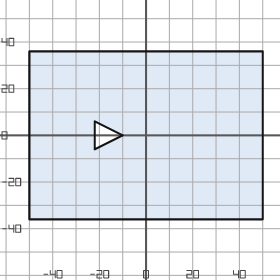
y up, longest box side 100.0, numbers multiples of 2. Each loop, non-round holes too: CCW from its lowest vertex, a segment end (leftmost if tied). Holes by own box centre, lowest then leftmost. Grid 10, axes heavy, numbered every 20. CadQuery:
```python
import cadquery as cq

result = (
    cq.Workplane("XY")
    .moveTo(-50.0, -36.0)
    .lineTo(50.0, -36.0)
    .lineTo(50.0, 36.0)
    .lineTo(-50.0, 36.0)
    .close()
    .moveTo(-22.0, -6.0)
    .lineTo(-10.0, 0.0)
    .lineTo(-22.0, 6.0)
    .close()
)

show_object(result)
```